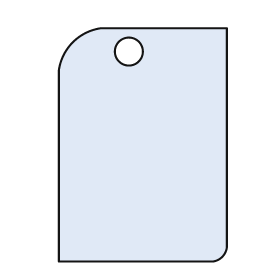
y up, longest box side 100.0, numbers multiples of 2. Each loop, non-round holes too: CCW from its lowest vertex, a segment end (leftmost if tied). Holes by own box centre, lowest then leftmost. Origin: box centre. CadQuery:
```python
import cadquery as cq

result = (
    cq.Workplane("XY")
    .moveTo(-36.0, -50.0)
    .lineTo(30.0, -50.0)
    .threePointArc((34.0, -48.0), (36.0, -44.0))
    .lineTo(36.0, 50.0)
    .lineTo(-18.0, 50.0)
    .threePointArc((-30.0, 44.0), (-36.0, 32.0))
    .close()
    .moveTo(-6.0, 40.0)
    .circle(6.0)
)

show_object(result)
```